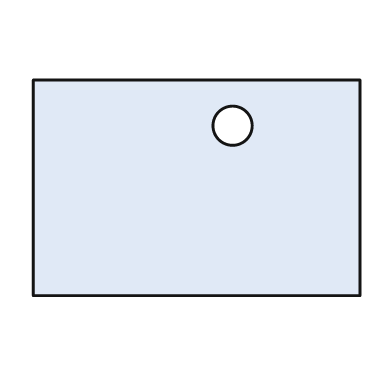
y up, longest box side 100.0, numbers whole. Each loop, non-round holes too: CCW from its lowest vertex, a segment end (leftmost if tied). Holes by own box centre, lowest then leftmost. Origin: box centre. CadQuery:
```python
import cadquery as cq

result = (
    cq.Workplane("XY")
    .moveTo(-50.0, -33.0)
    .lineTo(50.0, -33.0)
    .lineTo(50.0, 33.0)
    .lineTo(-50.0, 33.0)
    .close()
    .moveTo(11.0, 19.0)
    .circle(6.0)
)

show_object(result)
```